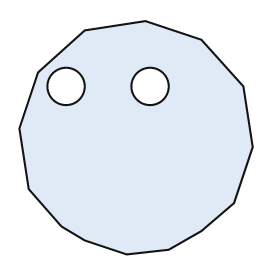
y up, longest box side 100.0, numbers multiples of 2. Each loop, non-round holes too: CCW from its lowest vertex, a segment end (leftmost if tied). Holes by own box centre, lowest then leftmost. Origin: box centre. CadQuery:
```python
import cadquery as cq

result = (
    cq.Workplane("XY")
    .moveTo(-4.0, -50.0)
    .lineTo(14.0, -48.0)
    .lineTo(28.0, -40.0)
    .lineTo(42.0, -28.0)
    .lineTo(50.0, -4.0)
    .lineTo(46.0, 22.0)
    .lineTo(28.0, 42.0)
    .lineTo(4.0, 50.0)
    .lineTo(-22.0, 46.0)
    .lineTo(-42.0, 28.0)
    .lineTo(-50.0, 4.0)
    .lineTo(-46.0, -22.0)
    .lineTo(-32.0, -38.0)
    .lineTo(-22.0, -44.0)
    .close()
    .moveTo(-30.0, 22.0)
    .circle(8.0)
    .moveTo(6.0, 22.0)
    .circle(8.0)
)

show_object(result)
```